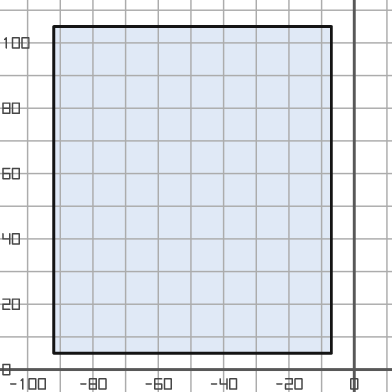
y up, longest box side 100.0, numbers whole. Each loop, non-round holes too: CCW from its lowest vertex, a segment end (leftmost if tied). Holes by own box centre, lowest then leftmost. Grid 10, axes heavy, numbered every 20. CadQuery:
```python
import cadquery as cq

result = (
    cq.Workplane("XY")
    .moveTo(-92.0, 5.0)
    .lineTo(-7.0, 5.0)
    .lineTo(-7.0, 105.0)
    .lineTo(-92.0, 105.0)
    .close()
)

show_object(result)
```